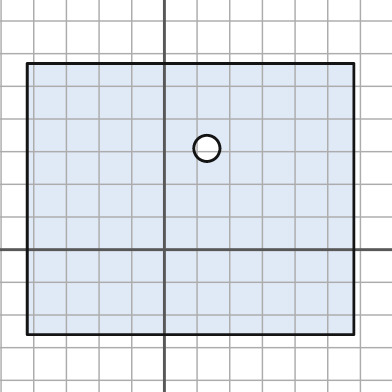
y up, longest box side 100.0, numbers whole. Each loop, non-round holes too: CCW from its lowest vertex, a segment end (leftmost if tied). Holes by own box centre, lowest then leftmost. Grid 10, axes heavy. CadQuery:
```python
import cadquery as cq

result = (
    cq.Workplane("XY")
    .moveTo(-42.0, -26.0)
    .lineTo(58.0, -26.0)
    .lineTo(58.0, 57.0)
    .lineTo(-42.0, 57.0)
    .close()
    .moveTo(13.0, 31.0)
    .circle(4.0)
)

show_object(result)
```